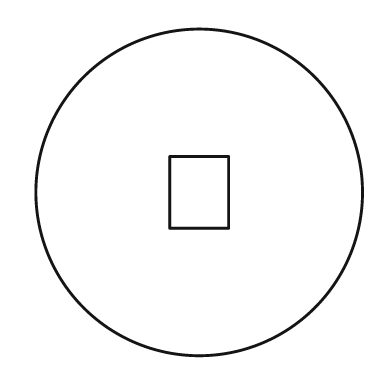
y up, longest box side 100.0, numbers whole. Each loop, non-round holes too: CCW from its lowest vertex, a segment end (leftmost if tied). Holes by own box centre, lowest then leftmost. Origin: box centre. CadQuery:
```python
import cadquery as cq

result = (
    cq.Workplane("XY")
    .moveTo(0.0, 0.0)
    .circle(50.0)
    .moveTo(-9.0, -11.0)
    .lineTo(9.0, -11.0)
    .lineTo(9.0, 11.0)
    .lineTo(-9.0, 11.0)
    .close()
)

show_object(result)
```